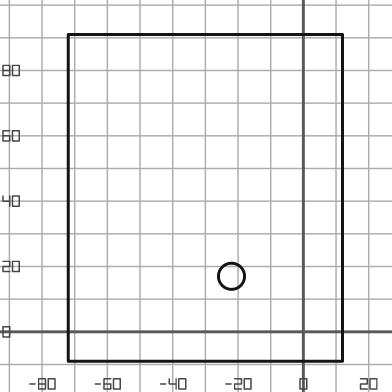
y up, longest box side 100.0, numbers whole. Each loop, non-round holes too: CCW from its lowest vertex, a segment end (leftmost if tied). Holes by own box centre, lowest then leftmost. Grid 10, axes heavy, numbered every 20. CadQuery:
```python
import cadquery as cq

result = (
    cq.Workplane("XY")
    .moveTo(-72.0, -9.0)
    .lineTo(12.0, -9.0)
    .lineTo(12.0, 91.0)
    .lineTo(-72.0, 91.0)
    .close()
    .moveTo(-22.0, 17.0)
    .circle(4.0)
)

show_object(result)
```